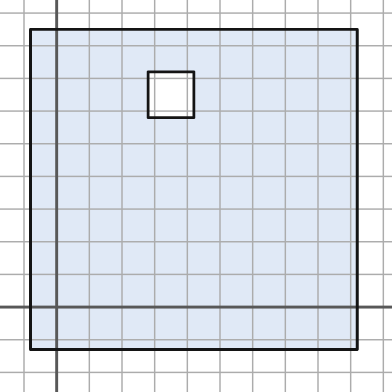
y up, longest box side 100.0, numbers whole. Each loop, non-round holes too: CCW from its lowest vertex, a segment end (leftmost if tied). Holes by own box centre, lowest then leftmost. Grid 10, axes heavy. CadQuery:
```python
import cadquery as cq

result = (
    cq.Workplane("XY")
    .moveTo(-8.0, -13.0)
    .lineTo(92.0, -13.0)
    .lineTo(92.0, 85.0)
    .lineTo(-8.0, 85.0)
    .close()
    .moveTo(28.0, 58.0)
    .lineTo(42.0, 58.0)
    .lineTo(42.0, 72.0)
    .lineTo(28.0, 72.0)
    .close()
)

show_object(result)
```